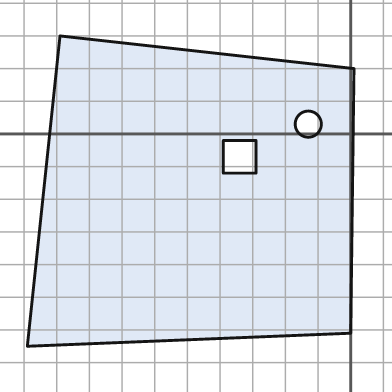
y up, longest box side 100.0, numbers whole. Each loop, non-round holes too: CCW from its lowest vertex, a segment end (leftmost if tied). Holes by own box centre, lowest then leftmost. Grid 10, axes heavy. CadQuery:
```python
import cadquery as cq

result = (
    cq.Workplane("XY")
    .moveTo(-99.0, -65.0)
    .lineTo(0.0, -61.0)
    .lineTo(1.0, 20.0)
    .lineTo(-89.0, 30.0)
    .close()
    .moveTo(-39.0, -12.0)
    .lineTo(-29.0, -12.0)
    .lineTo(-29.0, -2.0)
    .lineTo(-39.0, -2.0)
    .close()
    .moveTo(-13.0, 3.0)
    .circle(4.0)
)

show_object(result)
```